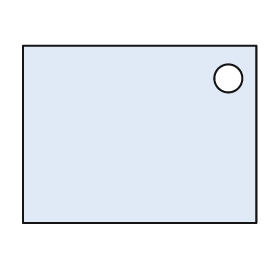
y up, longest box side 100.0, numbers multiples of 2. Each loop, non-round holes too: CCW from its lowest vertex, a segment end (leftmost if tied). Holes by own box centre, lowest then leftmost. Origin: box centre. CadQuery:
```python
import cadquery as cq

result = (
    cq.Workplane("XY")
    .moveTo(-50.0, -38.0)
    .lineTo(50.0, -38.0)
    .lineTo(50.0, 38.0)
    .lineTo(-50.0, 38.0)
    .close()
    .moveTo(38.0, 24.0)
    .circle(6.0)
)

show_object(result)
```